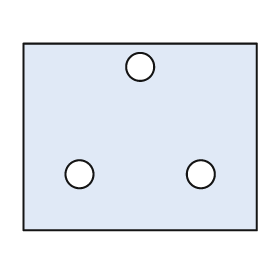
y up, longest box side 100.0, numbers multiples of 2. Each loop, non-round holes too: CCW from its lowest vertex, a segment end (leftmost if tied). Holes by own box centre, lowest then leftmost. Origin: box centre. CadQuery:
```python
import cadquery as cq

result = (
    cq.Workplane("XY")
    .moveTo(-50.0, -40.0)
    .lineTo(50.0, -40.0)
    .lineTo(50.0, 40.0)
    .lineTo(-50.0, 40.0)
    .close()
    .moveTo(-26.0, -16.0)
    .circle(6.0)
    .moveTo(26.0, -16.0)
    .circle(6.0)
    .moveTo(0.0, 30.0)
    .circle(6.0)
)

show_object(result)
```